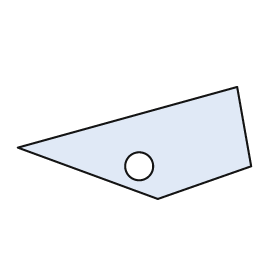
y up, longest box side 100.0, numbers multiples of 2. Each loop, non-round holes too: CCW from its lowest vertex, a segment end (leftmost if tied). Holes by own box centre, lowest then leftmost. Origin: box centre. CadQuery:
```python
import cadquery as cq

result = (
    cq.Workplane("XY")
    .moveTo(10.0, -24.0)
    .lineTo(50.0, -10.0)
    .lineTo(44.0, 24.0)
    .lineTo(-50.0, -2.0)
    .close()
    .moveTo(2.0, -10.0)
    .circle(6.0)
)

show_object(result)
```